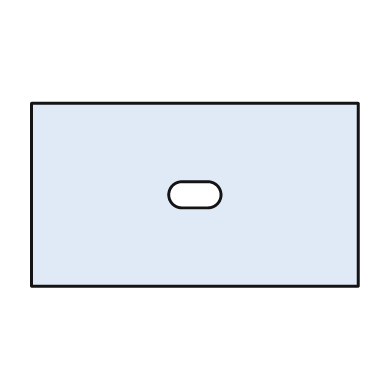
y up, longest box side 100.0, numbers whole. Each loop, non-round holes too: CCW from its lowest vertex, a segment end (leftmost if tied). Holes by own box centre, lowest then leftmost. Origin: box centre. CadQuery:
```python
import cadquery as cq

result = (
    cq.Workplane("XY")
    .moveTo(-50.0, -28.0)
    .lineTo(50.0, -28.0)
    .lineTo(50.0, 28.0)
    .lineTo(-50.0, 28.0)
    .close()
    .moveTo(-4.0, -4.0)
    .lineTo(4.0, -4.0)
    .threePointArc((8.0, 0.0), (4.0, 4.0))
    .lineTo(-4.0, 4.0)
    .threePointArc((-8.0, 0.0), (-4.0, -4.0))
    .close()
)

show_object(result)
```